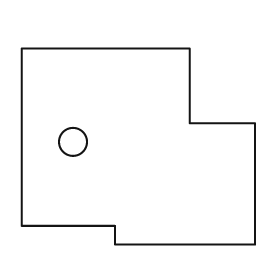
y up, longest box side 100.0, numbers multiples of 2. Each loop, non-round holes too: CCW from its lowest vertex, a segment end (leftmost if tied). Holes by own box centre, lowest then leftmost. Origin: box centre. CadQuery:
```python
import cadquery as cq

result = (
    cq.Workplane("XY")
    .moveTo(-10.0, -42.0)
    .lineTo(50.0, -42.0)
    .lineTo(50.0, 10.0)
    .lineTo(22.0, 10.0)
    .lineTo(22.0, 42.0)
    .lineTo(-50.0, 42.0)
    .lineTo(-50.0, -34.0)
    .lineTo(-10.0, -34.0)
    .close()
    .moveTo(-28.0, 2.0)
    .circle(6.0)
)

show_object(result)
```